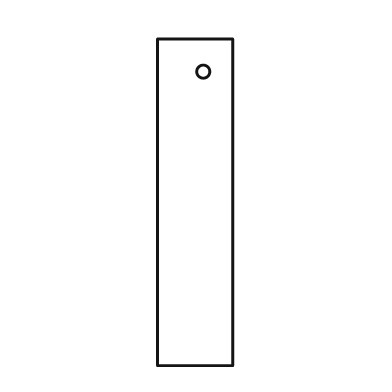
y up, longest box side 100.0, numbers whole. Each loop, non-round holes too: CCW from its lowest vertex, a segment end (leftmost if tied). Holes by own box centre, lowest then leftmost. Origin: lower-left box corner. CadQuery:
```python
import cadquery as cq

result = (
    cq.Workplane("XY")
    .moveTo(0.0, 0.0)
    .lineTo(23.0, 0.0)
    .lineTo(23.0, 100.0)
    .lineTo(0.0, 100.0)
    .close()
    .moveTo(14.0, 90.0)
    .circle(2.0)
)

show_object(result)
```